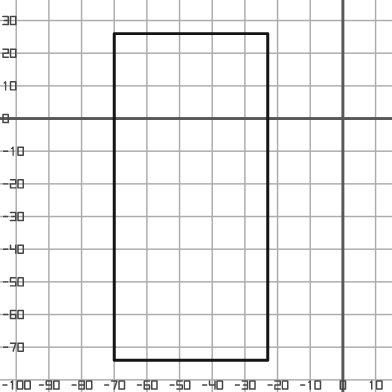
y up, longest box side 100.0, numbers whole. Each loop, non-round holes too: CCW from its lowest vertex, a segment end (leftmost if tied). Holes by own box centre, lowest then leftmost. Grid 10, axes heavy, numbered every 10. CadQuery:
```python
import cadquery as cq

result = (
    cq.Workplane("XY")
    .moveTo(-70.0, -74.0)
    .lineTo(-23.0, -74.0)
    .lineTo(-23.0, 26.0)
    .lineTo(-70.0, 26.0)
    .close()
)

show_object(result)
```